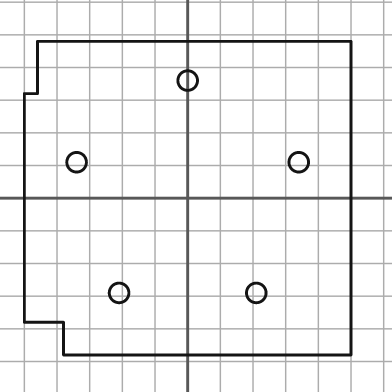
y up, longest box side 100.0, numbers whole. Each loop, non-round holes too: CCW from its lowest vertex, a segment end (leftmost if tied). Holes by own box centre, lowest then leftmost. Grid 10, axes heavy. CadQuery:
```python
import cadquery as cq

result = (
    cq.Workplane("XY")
    .moveTo(-38.0, -48.0)
    .lineTo(50.0, -48.0)
    .lineTo(50.0, 48.0)
    .lineTo(-46.0, 48.0)
    .lineTo(-46.0, 32.0)
    .lineTo(-50.0, 32.0)
    .lineTo(-50.0, -38.0)
    .lineTo(-38.0, -38.0)
    .close()
    .moveTo(-21.0, -29.0)
    .circle(3.0)
    .moveTo(21.0, -29.0)
    .circle(3.0)
    .moveTo(-34.0, 11.0)
    .circle(3.0)
    .moveTo(34.0, 11.0)
    .circle(3.0)
    .moveTo(0.0, 36.0)
    .circle(3.0)
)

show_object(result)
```